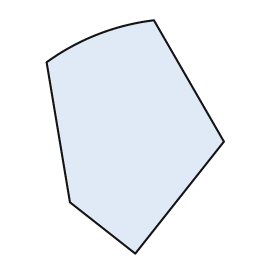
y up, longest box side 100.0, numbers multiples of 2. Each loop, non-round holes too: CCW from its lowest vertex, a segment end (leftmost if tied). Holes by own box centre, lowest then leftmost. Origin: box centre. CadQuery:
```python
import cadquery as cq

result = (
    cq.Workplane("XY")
    .moveTo(0.0, -50.0)
    .lineTo(38.0, -2.0)
    .lineTo(8.0, 50.0)
    .threePointArc((-16.0, 44.0), (-38.0, 32.0))
    .lineTo(-28.0, -28.0)
    .close()
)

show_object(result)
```